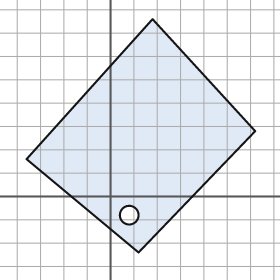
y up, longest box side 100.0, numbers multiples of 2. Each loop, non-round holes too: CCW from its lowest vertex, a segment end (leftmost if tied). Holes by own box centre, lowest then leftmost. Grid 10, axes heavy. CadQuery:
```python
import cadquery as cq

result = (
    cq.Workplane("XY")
    .moveTo(12.0, -24.0)
    .lineTo(62.0, 28.0)
    .lineTo(18.0, 76.0)
    .lineTo(-36.0, 16.0)
    .close()
    .moveTo(8.0, -8.0)
    .circle(4.0)
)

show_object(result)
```